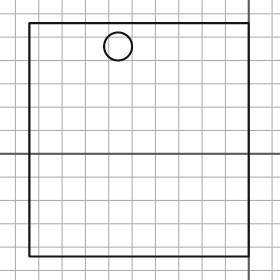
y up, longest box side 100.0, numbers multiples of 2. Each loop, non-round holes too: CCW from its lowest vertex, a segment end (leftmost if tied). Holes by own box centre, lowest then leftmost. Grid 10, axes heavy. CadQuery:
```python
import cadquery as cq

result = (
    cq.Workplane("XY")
    .moveTo(-94.0, -44.0)
    .lineTo(0.0, -44.0)
    .lineTo(0.0, 56.0)
    .lineTo(-94.0, 56.0)
    .close()
    .moveTo(-56.0, 46.0)
    .circle(6.0)
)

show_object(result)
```